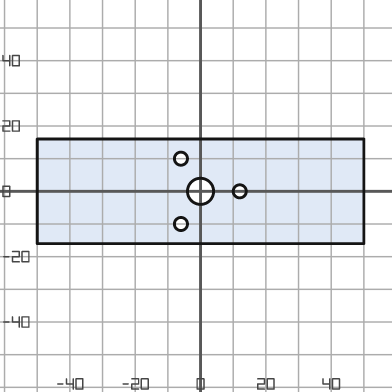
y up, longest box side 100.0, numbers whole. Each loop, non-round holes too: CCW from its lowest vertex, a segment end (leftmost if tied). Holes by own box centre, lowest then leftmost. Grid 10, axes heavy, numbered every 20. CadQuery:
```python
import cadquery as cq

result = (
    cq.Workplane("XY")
    .moveTo(-50.0, -16.0)
    .lineTo(50.0, -16.0)
    .lineTo(50.0, 16.0)
    .lineTo(-50.0, 16.0)
    .close()
    .moveTo(-6.0, -10.0)
    .circle(2.0)
    .moveTo(0.0, 0.0)
    .circle(4.0)
    .moveTo(12.0, 0.0)
    .circle(2.0)
    .moveTo(-6.0, 10.0)
    .circle(2.0)
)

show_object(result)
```